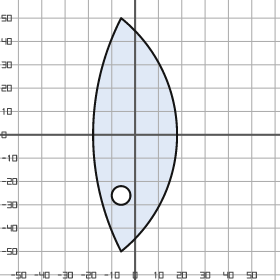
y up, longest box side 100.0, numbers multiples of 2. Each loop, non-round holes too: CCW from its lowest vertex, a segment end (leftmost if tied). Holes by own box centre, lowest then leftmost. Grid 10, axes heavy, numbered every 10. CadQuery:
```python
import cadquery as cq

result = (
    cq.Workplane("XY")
    .moveTo(-6.0, -50.0)
    .threePointArc((18.0, 0.0), (-6.0, 50.0))
    .threePointArc((-18.0, 0.0), (-6.0, -50.0))
    .close()
    .moveTo(-6.0, -26.0)
    .circle(4.0)
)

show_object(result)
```